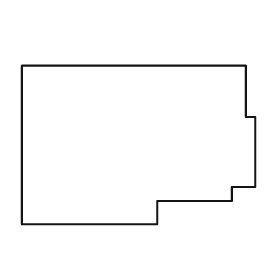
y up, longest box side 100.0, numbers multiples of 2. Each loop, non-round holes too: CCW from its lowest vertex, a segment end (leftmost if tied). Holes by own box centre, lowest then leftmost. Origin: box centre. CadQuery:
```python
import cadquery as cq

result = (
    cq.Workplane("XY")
    .moveTo(-50.0, -34.0)
    .lineTo(8.0, -34.0)
    .lineTo(8.0, -24.0)
    .lineTo(40.0, -24.0)
    .lineTo(40.0, -18.0)
    .lineTo(50.0, -18.0)
    .lineTo(50.0, 12.0)
    .lineTo(46.0, 12.0)
    .lineTo(46.0, 34.0)
    .lineTo(-50.0, 34.0)
    .close()
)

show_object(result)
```